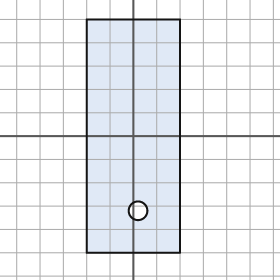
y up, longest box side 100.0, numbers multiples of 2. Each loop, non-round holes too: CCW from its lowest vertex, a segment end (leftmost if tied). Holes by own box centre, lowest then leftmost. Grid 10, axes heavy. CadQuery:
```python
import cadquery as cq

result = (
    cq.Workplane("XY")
    .moveTo(-20.0, -50.0)
    .lineTo(20.0, -50.0)
    .lineTo(20.0, 50.0)
    .lineTo(-20.0, 50.0)
    .close()
    .moveTo(2.0, -32.0)
    .circle(4.0)
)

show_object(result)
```